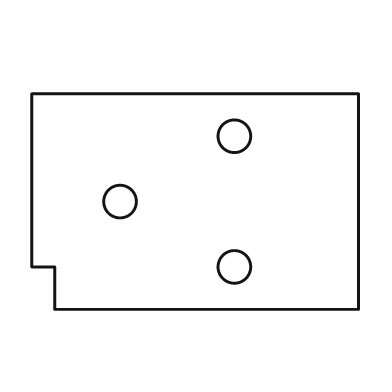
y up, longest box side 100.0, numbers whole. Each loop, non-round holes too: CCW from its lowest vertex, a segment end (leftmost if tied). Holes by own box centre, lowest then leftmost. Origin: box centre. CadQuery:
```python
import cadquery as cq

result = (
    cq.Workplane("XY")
    .moveTo(-43.0, -33.0)
    .lineTo(50.0, -33.0)
    .lineTo(50.0, 33.0)
    .lineTo(-50.0, 33.0)
    .lineTo(-50.0, -20.0)
    .lineTo(-43.0, -20.0)
    .close()
    .moveTo(12.0, -20.0)
    .circle(5.0)
    .moveTo(-23.0, 0.0)
    .circle(5.0)
    .moveTo(12.0, 20.0)
    .circle(5.0)
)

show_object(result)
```